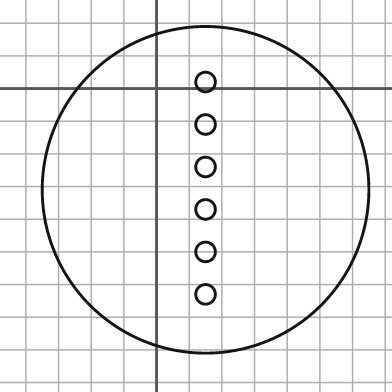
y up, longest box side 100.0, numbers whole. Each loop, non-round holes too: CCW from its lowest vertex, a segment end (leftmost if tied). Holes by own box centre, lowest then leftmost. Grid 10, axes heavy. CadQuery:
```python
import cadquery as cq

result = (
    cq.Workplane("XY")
    .moveTo(15.0, -31.0)
    .circle(50.0)
    .moveTo(15.0, -63.0)
    .circle(3.0)
    .moveTo(15.0, -50.0)
    .circle(3.0)
    .moveTo(15.0, -37.0)
    .circle(3.0)
    .moveTo(15.0, -24.0)
    .circle(3.0)
    .moveTo(15.0, -11.0)
    .circle(3.0)
    .moveTo(15.0, 2.0)
    .circle(3.0)
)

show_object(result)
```